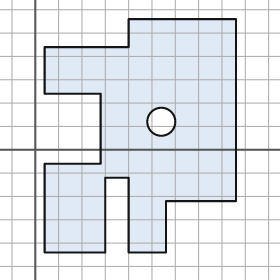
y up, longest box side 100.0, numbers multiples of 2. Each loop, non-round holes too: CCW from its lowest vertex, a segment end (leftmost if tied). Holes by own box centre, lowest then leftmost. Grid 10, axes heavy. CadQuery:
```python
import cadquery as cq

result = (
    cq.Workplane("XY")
    .moveTo(4.0, -44.0)
    .lineTo(30.0, -44.0)
    .lineTo(30.0, -12.0)
    .lineTo(40.0, -12.0)
    .lineTo(40.0, -44.0)
    .lineTo(56.0, -44.0)
    .lineTo(56.0, -22.0)
    .lineTo(86.0, -22.0)
    .lineTo(86.0, 56.0)
    .lineTo(40.0, 56.0)
    .lineTo(40.0, 44.0)
    .lineTo(4.0, 44.0)
    .lineTo(4.0, 24.0)
    .lineTo(28.0, 24.0)
    .lineTo(28.0, -6.0)
    .lineTo(4.0, -6.0)
    .close()
    .moveTo(54.0, 12.0)
    .circle(6.0)
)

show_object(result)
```